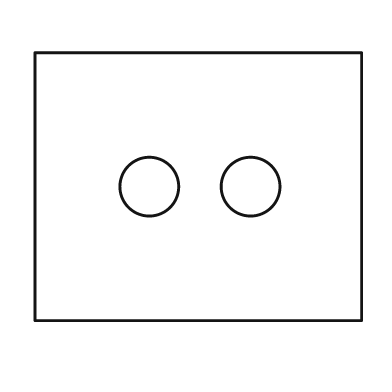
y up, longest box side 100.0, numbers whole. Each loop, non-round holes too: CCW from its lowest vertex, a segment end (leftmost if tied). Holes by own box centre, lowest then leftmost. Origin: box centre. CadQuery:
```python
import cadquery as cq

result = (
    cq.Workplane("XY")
    .moveTo(-50.0, -41.0)
    .lineTo(50.0, -41.0)
    .lineTo(50.0, 41.0)
    .lineTo(-50.0, 41.0)
    .close()
    .moveTo(-15.0, 0.0)
    .circle(9.0)
    .moveTo(16.0, 0.0)
    .circle(9.0)
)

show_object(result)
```